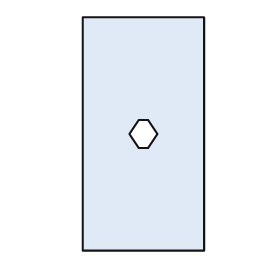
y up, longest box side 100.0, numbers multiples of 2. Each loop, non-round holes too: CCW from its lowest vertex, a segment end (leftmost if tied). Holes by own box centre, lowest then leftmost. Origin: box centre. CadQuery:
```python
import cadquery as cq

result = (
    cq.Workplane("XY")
    .moveTo(-26.0, -50.0)
    .lineTo(26.0, -50.0)
    .lineTo(26.0, 50.0)
    .lineTo(-26.0, 50.0)
    .close()
    .moveTo(-2.0, -6.0)
    .lineTo(2.0, -6.0)
    .lineTo(6.0, 0.0)
    .lineTo(2.0, 6.0)
    .lineTo(-2.0, 6.0)
    .lineTo(-6.0, 0.0)
    .close()
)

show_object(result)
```